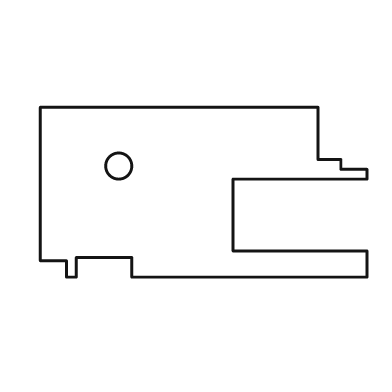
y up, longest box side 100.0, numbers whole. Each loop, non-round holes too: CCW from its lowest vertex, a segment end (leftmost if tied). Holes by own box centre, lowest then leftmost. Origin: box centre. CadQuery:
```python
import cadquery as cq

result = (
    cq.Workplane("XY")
    .moveTo(-42.0, -26.0)
    .lineTo(-39.0, -26.0)
    .lineTo(-39.0, -20.0)
    .lineTo(-22.0, -20.0)
    .lineTo(-22.0, -26.0)
    .lineTo(50.0, -26.0)
    .lineTo(50.0, -18.0)
    .lineTo(9.0, -18.0)
    .lineTo(9.0, 4.0)
    .lineTo(50.0, 4.0)
    .lineTo(50.0, 7.0)
    .lineTo(42.0, 7.0)
    .lineTo(42.0, 10.0)
    .lineTo(35.0, 10.0)
    .lineTo(35.0, 26.0)
    .lineTo(-50.0, 26.0)
    .lineTo(-50.0, -21.0)
    .lineTo(-42.0, -21.0)
    .close()
    .moveTo(-26.0, 8.0)
    .circle(4.0)
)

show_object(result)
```